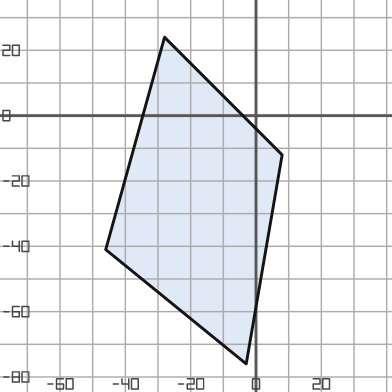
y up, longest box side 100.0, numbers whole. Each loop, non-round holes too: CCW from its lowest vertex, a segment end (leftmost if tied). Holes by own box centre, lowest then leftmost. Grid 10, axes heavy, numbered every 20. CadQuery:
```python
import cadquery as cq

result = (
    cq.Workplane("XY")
    .moveTo(-3.0, -76.0)
    .lineTo(8.0, -12.0)
    .lineTo(-28.0, 24.0)
    .lineTo(-46.0, -41.0)
    .close()
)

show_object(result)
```